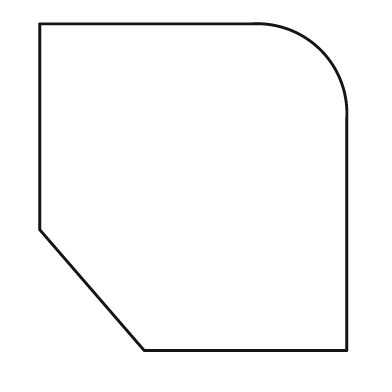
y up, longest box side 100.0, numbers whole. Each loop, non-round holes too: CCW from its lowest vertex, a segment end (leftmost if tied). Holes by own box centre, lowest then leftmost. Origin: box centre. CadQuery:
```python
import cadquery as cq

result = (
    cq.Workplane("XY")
    .moveTo(-15.0, -50.0)
    .lineTo(47.0, -50.0)
    .lineTo(47.0, 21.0)
    .threePointArc((39.0, 42.0), (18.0, 50.0))
    .lineTo(-47.0, 50.0)
    .lineTo(-47.0, -13.0)
    .close()
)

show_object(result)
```